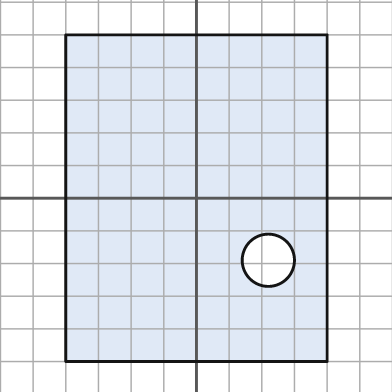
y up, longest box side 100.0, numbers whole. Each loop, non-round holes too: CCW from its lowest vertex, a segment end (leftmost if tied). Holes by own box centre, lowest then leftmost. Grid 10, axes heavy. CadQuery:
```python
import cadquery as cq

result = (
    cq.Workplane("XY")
    .moveTo(-40.0, -50.0)
    .lineTo(40.0, -50.0)
    .lineTo(40.0, 50.0)
    .lineTo(-40.0, 50.0)
    .close()
    .moveTo(22.0, -19.0)
    .circle(8.0)
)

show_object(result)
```